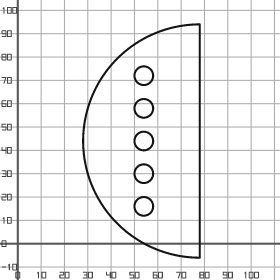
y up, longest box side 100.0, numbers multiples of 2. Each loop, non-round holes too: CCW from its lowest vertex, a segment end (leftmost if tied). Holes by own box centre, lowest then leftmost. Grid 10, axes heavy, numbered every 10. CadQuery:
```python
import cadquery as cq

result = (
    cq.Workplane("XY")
    .moveTo(78.0, -6.0)
    .lineTo(78.0, 94.0)
    .threePointArc((28.0, 44.0), (78.0, -6.0))
    .close()
    .moveTo(54.0, 16.0)
    .circle(4.0)
    .moveTo(54.0, 30.0)
    .circle(4.0)
    .moveTo(54.0, 44.0)
    .circle(4.0)
    .moveTo(54.0, 58.0)
    .circle(4.0)
    .moveTo(54.0, 72.0)
    .circle(4.0)
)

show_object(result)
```